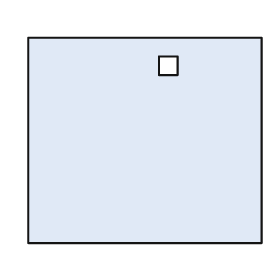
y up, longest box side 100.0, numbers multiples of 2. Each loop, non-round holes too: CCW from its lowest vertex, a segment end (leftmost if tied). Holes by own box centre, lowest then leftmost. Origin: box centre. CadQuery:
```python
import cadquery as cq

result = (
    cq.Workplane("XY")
    .moveTo(-50.0, -44.0)
    .lineTo(50.0, -44.0)
    .lineTo(50.0, 44.0)
    .lineTo(-50.0, 44.0)
    .close()
    .moveTo(6.0, 28.0)
    .lineTo(14.0, 28.0)
    .lineTo(14.0, 36.0)
    .lineTo(6.0, 36.0)
    .close()
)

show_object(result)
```